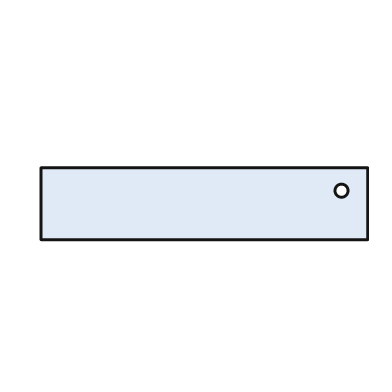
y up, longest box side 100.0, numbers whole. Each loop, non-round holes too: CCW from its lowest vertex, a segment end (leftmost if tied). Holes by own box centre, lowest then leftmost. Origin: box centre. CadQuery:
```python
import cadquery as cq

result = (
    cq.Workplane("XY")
    .moveTo(-50.0, -11.0)
    .lineTo(50.0, -11.0)
    .lineTo(50.0, 11.0)
    .lineTo(-50.0, 11.0)
    .close()
    .moveTo(42.0, 4.0)
    .circle(2.0)
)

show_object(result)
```